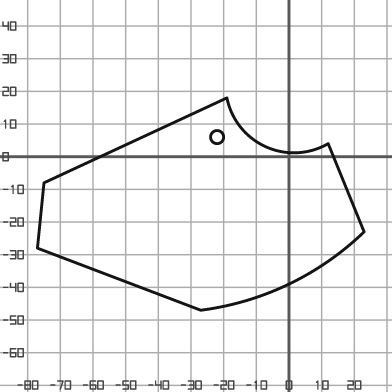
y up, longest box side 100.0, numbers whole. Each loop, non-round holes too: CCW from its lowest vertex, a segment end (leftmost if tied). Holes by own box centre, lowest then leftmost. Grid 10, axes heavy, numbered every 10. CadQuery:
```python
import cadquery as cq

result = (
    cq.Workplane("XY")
    .moveTo(-27.0, -47.0)
    .threePointArc((0.0, -39.0), (23.0, -23.0))
    .lineTo(12.0, 4.0)
    .threePointArc((-7.0, 3.0), (-19.0, 18.0))
    .lineTo(-75.0, -8.0)
    .lineTo(-77.0, -28.0)
    .close()
    .moveTo(-22.0, 6.0)
    .circle(2.0)
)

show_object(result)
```